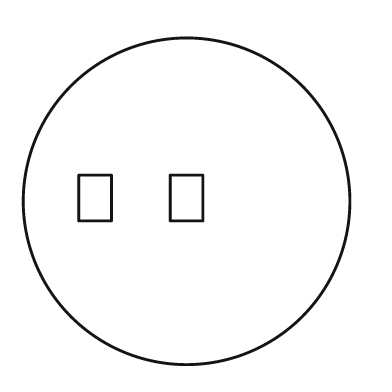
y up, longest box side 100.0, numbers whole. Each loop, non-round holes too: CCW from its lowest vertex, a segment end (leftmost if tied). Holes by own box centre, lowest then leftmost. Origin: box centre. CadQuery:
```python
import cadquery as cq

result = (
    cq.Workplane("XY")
    .moveTo(0.0, 0.0)
    .circle(50.0)
    .moveTo(-33.0, -6.0)
    .lineTo(-23.0, -6.0)
    .lineTo(-23.0, 8.0)
    .lineTo(-33.0, 8.0)
    .close()
    .moveTo(-5.0, -6.0)
    .lineTo(5.0, -6.0)
    .lineTo(5.0, 8.0)
    .lineTo(-5.0, 8.0)
    .close()
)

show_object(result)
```